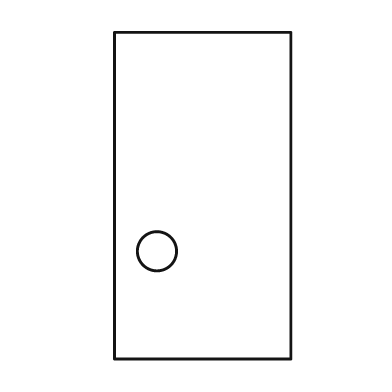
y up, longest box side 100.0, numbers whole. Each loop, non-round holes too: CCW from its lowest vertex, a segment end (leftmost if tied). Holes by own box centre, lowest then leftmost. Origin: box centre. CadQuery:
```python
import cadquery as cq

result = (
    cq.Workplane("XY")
    .moveTo(-27.0, -50.0)
    .lineTo(27.0, -50.0)
    .lineTo(27.0, 50.0)
    .lineTo(-27.0, 50.0)
    .close()
    .moveTo(-14.0, -17.0)
    .circle(6.0)
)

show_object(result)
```